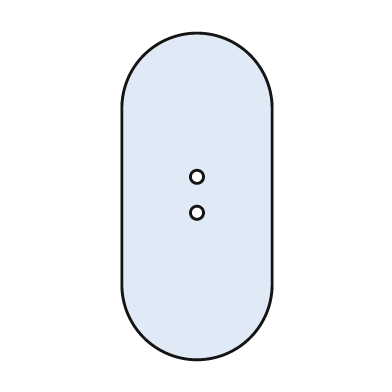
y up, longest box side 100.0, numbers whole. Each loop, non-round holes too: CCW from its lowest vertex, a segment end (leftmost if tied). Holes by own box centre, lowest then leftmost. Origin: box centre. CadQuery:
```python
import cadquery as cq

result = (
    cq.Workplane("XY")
    .moveTo(-23.0, -27.0)
    .threePointArc((0.0, -50.0), (23.0, -27.0))
    .lineTo(23.0, 27.0)
    .threePointArc((0.0, 50.0), (-23.0, 27.0))
    .close()
    .moveTo(0.0, -5.0)
    .circle(2.0)
    .moveTo(0.0, 6.0)
    .circle(2.0)
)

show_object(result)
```